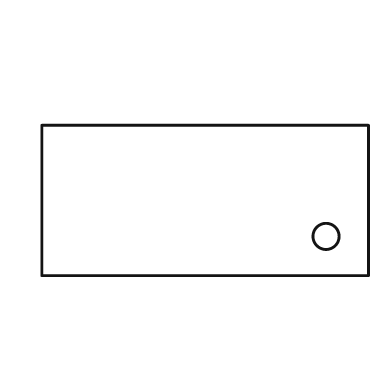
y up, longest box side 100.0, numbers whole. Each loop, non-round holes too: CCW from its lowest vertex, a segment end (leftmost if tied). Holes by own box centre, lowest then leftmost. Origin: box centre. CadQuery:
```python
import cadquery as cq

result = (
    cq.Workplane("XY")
    .moveTo(-50.0, -23.0)
    .lineTo(50.0, -23.0)
    .lineTo(50.0, 23.0)
    .lineTo(-50.0, 23.0)
    .close()
    .moveTo(37.0, -11.0)
    .circle(4.0)
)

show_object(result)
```